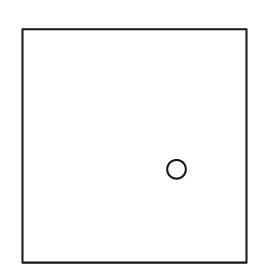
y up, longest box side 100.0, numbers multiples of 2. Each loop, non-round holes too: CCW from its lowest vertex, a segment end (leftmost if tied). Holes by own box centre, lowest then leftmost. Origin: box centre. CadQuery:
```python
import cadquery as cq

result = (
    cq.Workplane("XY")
    .moveTo(-48.0, -50.0)
    .lineTo(48.0, -50.0)
    .lineTo(48.0, 50.0)
    .lineTo(-48.0, 50.0)
    .close()
    .moveTo(18.0, -10.0)
    .circle(4.0)
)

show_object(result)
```